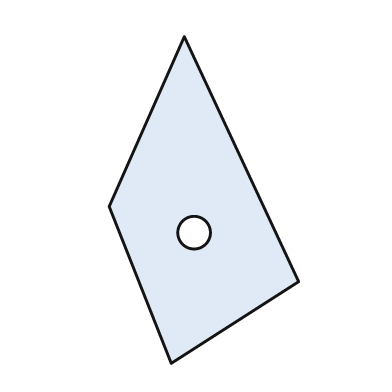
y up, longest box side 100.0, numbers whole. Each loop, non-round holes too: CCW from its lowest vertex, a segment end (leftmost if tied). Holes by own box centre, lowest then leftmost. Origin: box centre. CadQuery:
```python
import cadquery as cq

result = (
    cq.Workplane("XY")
    .moveTo(-10.0, -50.0)
    .lineTo(29.0, -25.0)
    .lineTo(-6.0, 50.0)
    .lineTo(-29.0, -2.0)
    .close()
    .moveTo(-3.0, -10.0)
    .circle(5.0)
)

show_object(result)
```